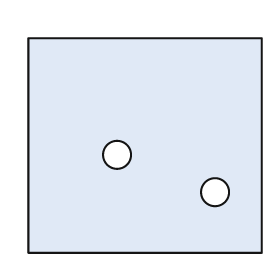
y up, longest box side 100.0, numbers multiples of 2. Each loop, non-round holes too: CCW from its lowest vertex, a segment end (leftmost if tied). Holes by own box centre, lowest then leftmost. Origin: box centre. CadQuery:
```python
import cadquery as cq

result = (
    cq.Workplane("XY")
    .moveTo(-50.0, -46.0)
    .lineTo(50.0, -46.0)
    .lineTo(50.0, 46.0)
    .lineTo(-50.0, 46.0)
    .close()
    .moveTo(30.0, -20.0)
    .circle(6.0)
    .moveTo(-12.0, -4.0)
    .circle(6.0)
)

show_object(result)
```